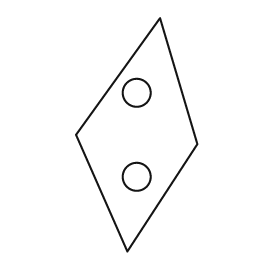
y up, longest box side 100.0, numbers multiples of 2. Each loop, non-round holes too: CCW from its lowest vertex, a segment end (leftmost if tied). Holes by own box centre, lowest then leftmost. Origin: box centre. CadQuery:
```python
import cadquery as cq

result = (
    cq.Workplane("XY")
    .moveTo(-4.0, -50.0)
    .lineTo(26.0, -4.0)
    .lineTo(10.0, 50.0)
    .lineTo(-26.0, 0.0)
    .close()
    .moveTo(0.0, -18.0)
    .circle(6.0)
    .moveTo(0.0, 18.0)
    .circle(6.0)
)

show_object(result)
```